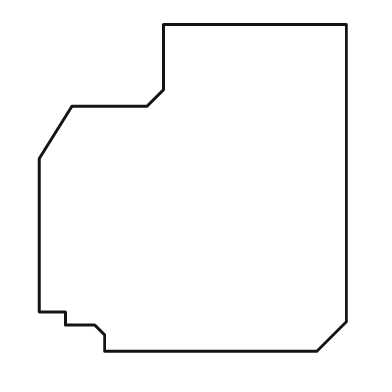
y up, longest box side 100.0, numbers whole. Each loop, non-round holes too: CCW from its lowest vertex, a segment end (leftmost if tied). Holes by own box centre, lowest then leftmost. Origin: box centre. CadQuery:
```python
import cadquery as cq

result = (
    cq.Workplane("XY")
    .moveTo(-27.0, -50.0)
    .lineTo(38.0, -50.0)
    .lineTo(47.0, -41.0)
    .lineTo(47.0, 50.0)
    .lineTo(-9.0, 50.0)
    .lineTo(-9.0, 30.0)
    .lineTo(-14.0, 25.0)
    .lineTo(-37.0, 25.0)
    .lineTo(-47.0, 9.0)
    .lineTo(-47.0, -38.0)
    .lineTo(-39.0, -38.0)
    .lineTo(-39.0, -42.0)
    .lineTo(-30.0, -42.0)
    .lineTo(-27.0, -45.0)
    .close()
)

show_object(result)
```